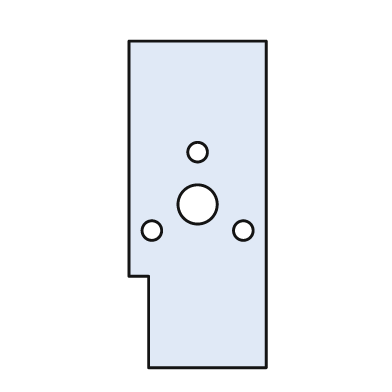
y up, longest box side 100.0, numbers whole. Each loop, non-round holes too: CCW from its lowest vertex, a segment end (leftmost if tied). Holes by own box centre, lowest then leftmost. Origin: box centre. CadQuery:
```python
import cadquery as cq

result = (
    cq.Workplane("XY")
    .moveTo(-15.0, -50.0)
    .lineTo(21.0, -50.0)
    .lineTo(21.0, 50.0)
    .lineTo(-21.0, 50.0)
    .lineTo(-21.0, -22.0)
    .lineTo(-15.0, -22.0)
    .close()
    .moveTo(-14.0, -8.0)
    .circle(3.0)
    .moveTo(14.0, -8.0)
    .circle(3.0)
    .moveTo(0.0, 0.0)
    .circle(6.0)
    .moveTo(0.0, 16.0)
    .circle(3.0)
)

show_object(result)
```